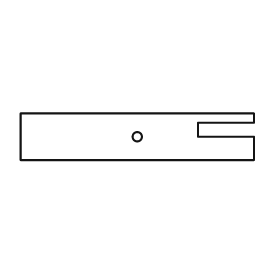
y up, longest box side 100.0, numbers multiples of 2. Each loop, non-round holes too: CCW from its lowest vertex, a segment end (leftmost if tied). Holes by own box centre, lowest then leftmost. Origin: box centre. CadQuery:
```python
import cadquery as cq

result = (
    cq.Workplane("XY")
    .moveTo(-50.0, -10.0)
    .lineTo(50.0, -10.0)
    .lineTo(50.0, 0.0)
    .lineTo(26.0, 0.0)
    .lineTo(26.0, 6.0)
    .lineTo(50.0, 6.0)
    .lineTo(50.0, 10.0)
    .lineTo(-50.0, 10.0)
    .close()
    .moveTo(0.0, 0.0)
    .circle(2.0)
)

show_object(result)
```